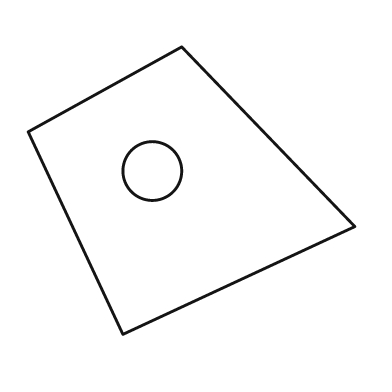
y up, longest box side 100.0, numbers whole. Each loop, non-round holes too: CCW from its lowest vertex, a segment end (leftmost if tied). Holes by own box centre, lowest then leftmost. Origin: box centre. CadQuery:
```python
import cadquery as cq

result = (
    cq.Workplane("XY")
    .moveTo(-21.0, -44.0)
    .lineTo(50.0, -11.0)
    .lineTo(-3.0, 44.0)
    .lineTo(-50.0, 18.0)
    .close()
    .moveTo(-12.0, 6.0)
    .circle(9.0)
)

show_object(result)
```